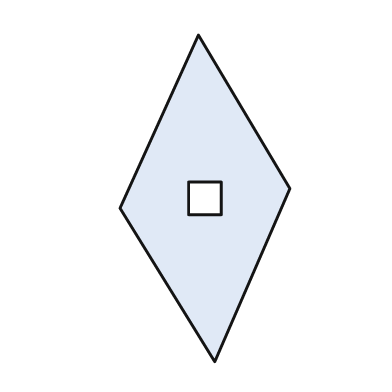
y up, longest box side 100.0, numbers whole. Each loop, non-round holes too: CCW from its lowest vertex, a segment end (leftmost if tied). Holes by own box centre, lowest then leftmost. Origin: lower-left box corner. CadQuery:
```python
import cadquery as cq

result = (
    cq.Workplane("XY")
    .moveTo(29.0, 0.0)
    .lineTo(52.0, 53.0)
    .lineTo(24.0, 100.0)
    .lineTo(0.0, 47.0)
    .close()
    .moveTo(21.0, 45.0)
    .lineTo(31.0, 45.0)
    .lineTo(31.0, 55.0)
    .lineTo(21.0, 55.0)
    .close()
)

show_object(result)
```